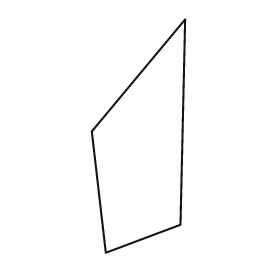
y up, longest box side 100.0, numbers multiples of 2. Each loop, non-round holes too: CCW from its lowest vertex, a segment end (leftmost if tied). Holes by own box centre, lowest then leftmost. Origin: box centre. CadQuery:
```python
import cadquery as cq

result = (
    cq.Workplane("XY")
    .moveTo(-14.0, -50.0)
    .lineTo(18.0, -38.0)
    .lineTo(20.0, 50.0)
    .lineTo(-20.0, 2.0)
    .close()
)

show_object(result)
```